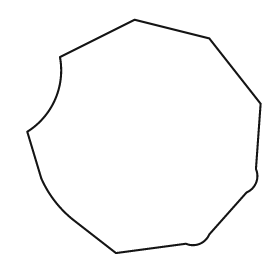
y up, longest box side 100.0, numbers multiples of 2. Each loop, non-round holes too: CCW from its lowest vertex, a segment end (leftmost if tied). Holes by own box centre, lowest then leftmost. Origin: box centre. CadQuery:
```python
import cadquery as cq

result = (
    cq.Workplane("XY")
    .moveTo(-12.0, -50.0)
    .lineTo(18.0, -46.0)
    .threePointArc((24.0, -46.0), (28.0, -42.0))
    .lineTo(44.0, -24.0)
    .threePointArc((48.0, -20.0), (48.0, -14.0))
    .lineTo(50.0, 14.0)
    .lineTo(28.0, 42.0)
    .lineTo(-4.0, 50.0)
    .lineTo(-36.0, 34.0)
    .threePointArc((-38.0, 16.0), (-50.0, 2.0))
    .lineTo(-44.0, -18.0)
    .threePointArc((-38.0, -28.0), (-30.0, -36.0))
    .close()
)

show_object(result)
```